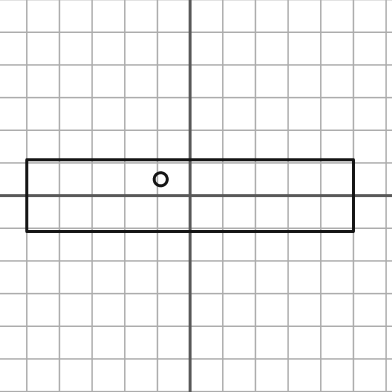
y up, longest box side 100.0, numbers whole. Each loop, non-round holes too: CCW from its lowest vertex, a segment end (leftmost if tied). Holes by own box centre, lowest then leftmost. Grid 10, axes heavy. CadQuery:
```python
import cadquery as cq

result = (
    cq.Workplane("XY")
    .moveTo(-50.0, -11.0)
    .lineTo(50.0, -11.0)
    .lineTo(50.0, 11.0)
    .lineTo(-50.0, 11.0)
    .close()
    .moveTo(-9.0, 5.0)
    .circle(2.0)
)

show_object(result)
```